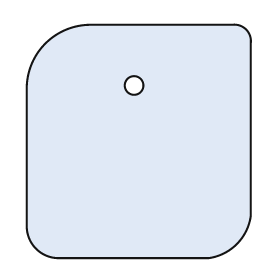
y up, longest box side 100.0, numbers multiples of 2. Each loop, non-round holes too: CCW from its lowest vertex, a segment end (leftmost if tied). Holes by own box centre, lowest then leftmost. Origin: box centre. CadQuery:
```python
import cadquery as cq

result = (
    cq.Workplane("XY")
    .moveTo(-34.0, -50.0)
    .lineTo(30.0, -50.0)
    .threePointArc((42.0, -44.0), (48.0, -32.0))
    .lineTo(48.0, 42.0)
    .threePointArc((46.0, 48.0), (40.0, 50.0))
    .lineTo(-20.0, 50.0)
    .threePointArc((-40.0, 42.0), (-48.0, 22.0))
    .lineTo(-48.0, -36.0)
    .threePointArc((-44.0, -46.0), (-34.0, -50.0))
    .close()
    .moveTo(-2.0, 24.0)
    .circle(4.0)
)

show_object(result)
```